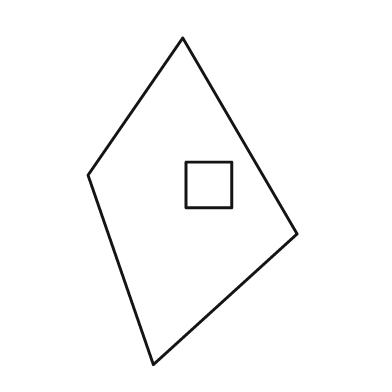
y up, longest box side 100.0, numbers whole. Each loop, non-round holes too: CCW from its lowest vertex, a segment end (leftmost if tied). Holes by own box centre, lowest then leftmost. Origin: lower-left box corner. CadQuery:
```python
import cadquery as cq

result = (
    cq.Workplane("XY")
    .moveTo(20.0, 0.0)
    .lineTo(64.0, 40.0)
    .lineTo(29.0, 100.0)
    .lineTo(0.0, 58.0)
    .close()
    .moveTo(30.0, 48.0)
    .lineTo(44.0, 48.0)
    .lineTo(44.0, 62.0)
    .lineTo(30.0, 62.0)
    .close()
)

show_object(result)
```